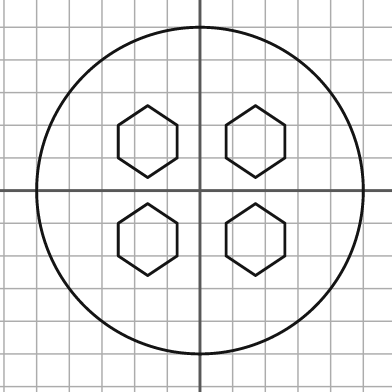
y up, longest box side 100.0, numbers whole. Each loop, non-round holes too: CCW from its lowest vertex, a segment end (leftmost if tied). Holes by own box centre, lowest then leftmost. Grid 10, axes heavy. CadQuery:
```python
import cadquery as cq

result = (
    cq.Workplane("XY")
    .moveTo(0.0, 0.0)
    .circle(50.0)
    .moveTo(-16.0, -26.0)
    .lineTo(-7.0, -20.0)
    .lineTo(-7.0, -10.0)
    .lineTo(-16.0, -4.0)
    .lineTo(-25.0, -10.0)
    .lineTo(-25.0, -20.0)
    .close()
    .moveTo(17.0, -26.0)
    .lineTo(26.0, -20.0)
    .lineTo(26.0, -10.0)
    .lineTo(17.0, -4.0)
    .lineTo(8.0, -10.0)
    .lineTo(8.0, -20.0)
    .close()
    .moveTo(-16.0, 4.0)
    .lineTo(-7.0, 10.0)
    .lineTo(-7.0, 20.0)
    .lineTo(-16.0, 26.0)
    .lineTo(-25.0, 20.0)
    .lineTo(-25.0, 10.0)
    .close()
    .moveTo(17.0, 4.0)
    .lineTo(26.0, 10.0)
    .lineTo(26.0, 20.0)
    .lineTo(17.0, 26.0)
    .lineTo(8.0, 20.0)
    .lineTo(8.0, 10.0)
    .close()
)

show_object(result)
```